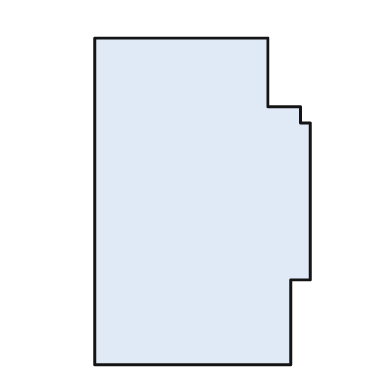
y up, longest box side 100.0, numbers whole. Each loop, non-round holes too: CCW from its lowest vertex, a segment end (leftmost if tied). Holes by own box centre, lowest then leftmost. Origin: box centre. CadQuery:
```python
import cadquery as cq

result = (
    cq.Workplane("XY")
    .moveTo(-33.0, -50.0)
    .lineTo(27.0, -50.0)
    .lineTo(27.0, -24.0)
    .lineTo(33.0, -24.0)
    .lineTo(33.0, 24.0)
    .lineTo(30.0, 24.0)
    .lineTo(30.0, 29.0)
    .lineTo(20.0, 29.0)
    .lineTo(20.0, 50.0)
    .lineTo(-33.0, 50.0)
    .close()
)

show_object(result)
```